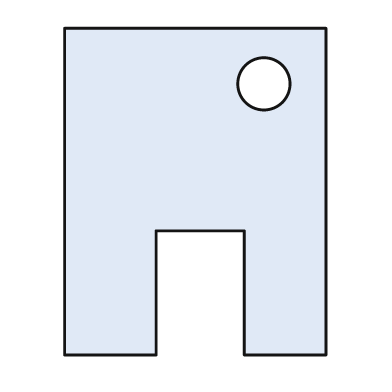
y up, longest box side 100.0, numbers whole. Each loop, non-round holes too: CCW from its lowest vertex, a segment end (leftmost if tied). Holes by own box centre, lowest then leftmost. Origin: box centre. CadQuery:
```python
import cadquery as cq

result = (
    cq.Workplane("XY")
    .moveTo(-40.0, -50.0)
    .lineTo(-12.0, -50.0)
    .lineTo(-12.0, -12.0)
    .lineTo(15.0, -12.0)
    .lineTo(15.0, -50.0)
    .lineTo(40.0, -50.0)
    .lineTo(40.0, 50.0)
    .lineTo(-40.0, 50.0)
    .close()
    .moveTo(21.0, 33.0)
    .circle(8.0)
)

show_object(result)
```